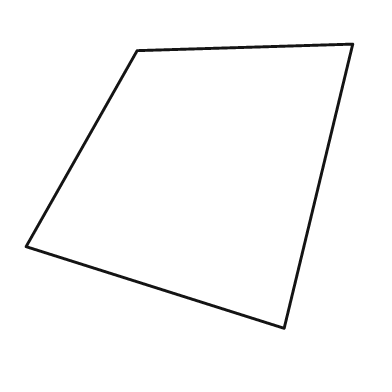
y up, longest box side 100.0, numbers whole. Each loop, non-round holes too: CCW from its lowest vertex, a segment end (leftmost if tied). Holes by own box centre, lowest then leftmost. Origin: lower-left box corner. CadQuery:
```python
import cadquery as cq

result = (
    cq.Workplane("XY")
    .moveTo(79.0, 0.0)
    .lineTo(100.0, 87.0)
    .lineTo(34.0, 85.0)
    .lineTo(0.0, 25.0)
    .close()
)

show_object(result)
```